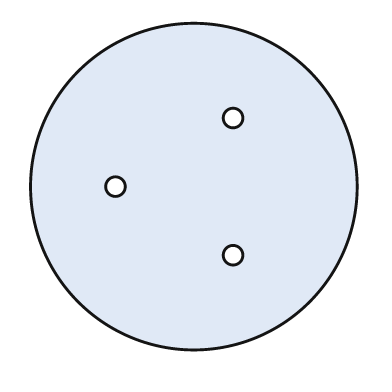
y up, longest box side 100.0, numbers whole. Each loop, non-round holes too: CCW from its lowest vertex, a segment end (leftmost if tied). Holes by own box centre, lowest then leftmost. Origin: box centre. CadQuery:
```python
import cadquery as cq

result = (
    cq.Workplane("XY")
    .moveTo(0.0, 0.0)
    .circle(50.0)
    .moveTo(12.0, -21.0)
    .circle(3.0)
    .moveTo(-24.0, 0.0)
    .circle(3.0)
    .moveTo(12.0, 21.0)
    .circle(3.0)
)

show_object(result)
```